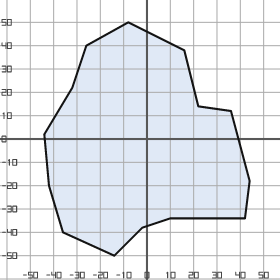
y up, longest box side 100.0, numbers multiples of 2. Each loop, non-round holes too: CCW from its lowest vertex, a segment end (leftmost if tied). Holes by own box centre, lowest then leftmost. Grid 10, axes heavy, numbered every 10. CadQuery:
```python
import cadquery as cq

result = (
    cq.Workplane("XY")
    .moveTo(-14.0, -50.0)
    .lineTo(-2.0, -38.0)
    .lineTo(10.0, -34.0)
    .lineTo(42.0, -34.0)
    .lineTo(44.0, -18.0)
    .lineTo(36.0, 12.0)
    .lineTo(22.0, 14.0)
    .lineTo(16.0, 38.0)
    .lineTo(-8.0, 50.0)
    .lineTo(-26.0, 40.0)
    .lineTo(-32.0, 22.0)
    .lineTo(-44.0, 2.0)
    .lineTo(-42.0, -20.0)
    .lineTo(-36.0, -40.0)
    .close()
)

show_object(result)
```